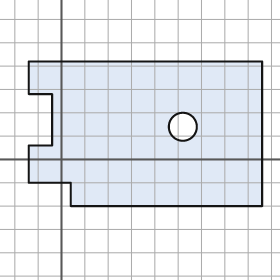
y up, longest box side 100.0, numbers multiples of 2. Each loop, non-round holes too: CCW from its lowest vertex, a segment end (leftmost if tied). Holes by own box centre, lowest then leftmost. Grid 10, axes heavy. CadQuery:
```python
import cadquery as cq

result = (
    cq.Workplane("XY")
    .moveTo(4.0, -20.0)
    .lineTo(86.0, -20.0)
    .lineTo(86.0, 42.0)
    .lineTo(-14.0, 42.0)
    .lineTo(-14.0, 28.0)
    .lineTo(-4.0, 28.0)
    .lineTo(-4.0, 6.0)
    .lineTo(-14.0, 6.0)
    .lineTo(-14.0, -10.0)
    .lineTo(4.0, -10.0)
    .close()
    .moveTo(52.0, 14.0)
    .circle(6.0)
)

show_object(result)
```